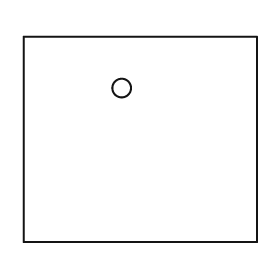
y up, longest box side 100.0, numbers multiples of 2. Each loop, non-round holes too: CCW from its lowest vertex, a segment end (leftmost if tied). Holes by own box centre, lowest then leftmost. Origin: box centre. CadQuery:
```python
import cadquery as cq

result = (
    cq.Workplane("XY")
    .moveTo(-50.0, -44.0)
    .lineTo(50.0, -44.0)
    .lineTo(50.0, 44.0)
    .lineTo(-50.0, 44.0)
    .close()
    .moveTo(-8.0, 22.0)
    .circle(4.0)
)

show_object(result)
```